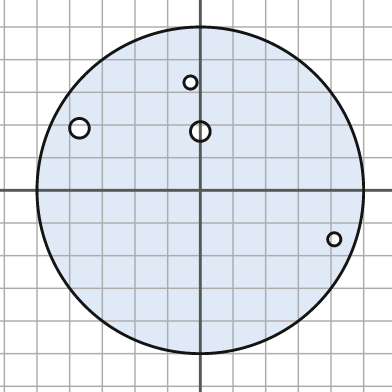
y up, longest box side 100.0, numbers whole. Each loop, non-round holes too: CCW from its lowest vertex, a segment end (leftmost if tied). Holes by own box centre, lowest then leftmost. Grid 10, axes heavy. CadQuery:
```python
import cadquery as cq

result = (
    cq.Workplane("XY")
    .moveTo(0.0, 0.0)
    .circle(50.0)
    .moveTo(41.0, -15.0)
    .circle(2.0)
    .moveTo(0.0, 18.0)
    .circle(3.0)
    .moveTo(-37.0, 19.0)
    .circle(3.0)
    .moveTo(-3.0, 33.0)
    .circle(2.0)
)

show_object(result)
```